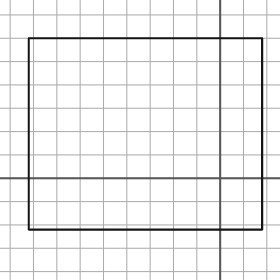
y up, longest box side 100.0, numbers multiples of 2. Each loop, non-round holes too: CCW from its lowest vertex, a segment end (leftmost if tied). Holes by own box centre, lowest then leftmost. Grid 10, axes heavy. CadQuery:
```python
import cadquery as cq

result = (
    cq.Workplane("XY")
    .moveTo(-82.0, -22.0)
    .lineTo(18.0, -22.0)
    .lineTo(18.0, 60.0)
    .lineTo(-82.0, 60.0)
    .close()
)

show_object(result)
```